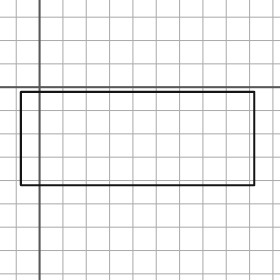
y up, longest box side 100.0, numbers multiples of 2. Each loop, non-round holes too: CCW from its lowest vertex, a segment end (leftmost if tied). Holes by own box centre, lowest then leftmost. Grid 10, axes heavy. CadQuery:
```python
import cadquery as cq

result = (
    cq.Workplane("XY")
    .moveTo(-8.0, -42.0)
    .lineTo(92.0, -42.0)
    .lineTo(92.0, -2.0)
    .lineTo(-8.0, -2.0)
    .close()
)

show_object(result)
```